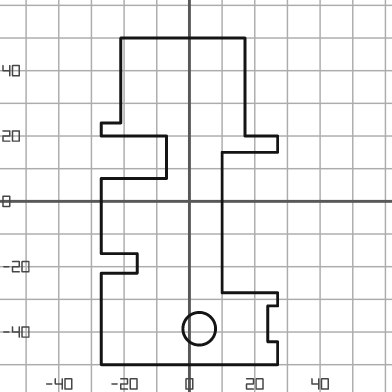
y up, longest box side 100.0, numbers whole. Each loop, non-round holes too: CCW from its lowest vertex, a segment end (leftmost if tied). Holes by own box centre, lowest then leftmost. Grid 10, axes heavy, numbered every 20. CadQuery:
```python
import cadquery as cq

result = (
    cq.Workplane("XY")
    .moveTo(-27.0, -50.0)
    .lineTo(27.0, -50.0)
    .lineTo(27.0, -43.0)
    .lineTo(24.0, -43.0)
    .lineTo(24.0, -32.0)
    .lineTo(27.0, -32.0)
    .lineTo(27.0, -28.0)
    .lineTo(10.0, -28.0)
    .lineTo(10.0, 15.0)
    .lineTo(27.0, 15.0)
    .lineTo(27.0, 20.0)
    .lineTo(17.0, 20.0)
    .lineTo(17.0, 50.0)
    .lineTo(-21.0, 50.0)
    .lineTo(-21.0, 24.0)
    .lineTo(-27.0, 24.0)
    .lineTo(-27.0, 20.0)
    .lineTo(-7.0, 20.0)
    .lineTo(-7.0, 7.0)
    .lineTo(-27.0, 7.0)
    .lineTo(-27.0, -16.0)
    .lineTo(-16.0, -16.0)
    .lineTo(-16.0, -22.0)
    .lineTo(-27.0, -22.0)
    .close()
    .moveTo(3.0, -39.0)
    .circle(5.0)
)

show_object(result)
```